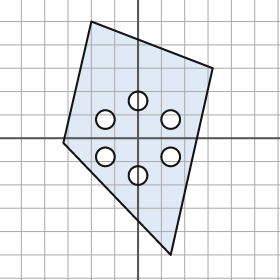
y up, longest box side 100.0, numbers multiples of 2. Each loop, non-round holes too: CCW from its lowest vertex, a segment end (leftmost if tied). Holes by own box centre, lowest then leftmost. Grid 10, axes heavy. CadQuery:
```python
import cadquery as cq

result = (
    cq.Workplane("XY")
    .moveTo(14.0, -50.0)
    .lineTo(32.0, 30.0)
    .lineTo(-20.0, 50.0)
    .lineTo(-32.0, -2.0)
    .close()
    .moveTo(0.0, -16.0)
    .circle(4.0)
    .moveTo(-14.0, -8.0)
    .circle(4.0)
    .moveTo(14.0, -8.0)
    .circle(4.0)
    .moveTo(-14.0, 8.0)
    .circle(4.0)
    .moveTo(14.0, 8.0)
    .circle(4.0)
    .moveTo(0.0, 16.0)
    .circle(4.0)
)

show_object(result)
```